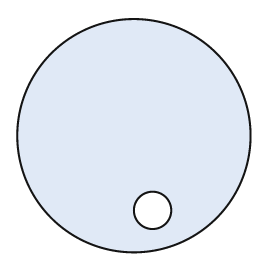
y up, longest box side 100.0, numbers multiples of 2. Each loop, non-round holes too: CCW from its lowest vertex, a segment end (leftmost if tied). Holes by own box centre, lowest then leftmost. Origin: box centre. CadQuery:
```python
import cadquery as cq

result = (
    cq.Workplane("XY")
    .moveTo(0.0, 0.0)
    .circle(50.0)
    .moveTo(8.0, -32.0)
    .circle(8.0)
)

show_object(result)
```